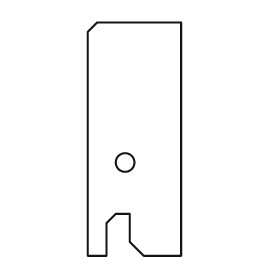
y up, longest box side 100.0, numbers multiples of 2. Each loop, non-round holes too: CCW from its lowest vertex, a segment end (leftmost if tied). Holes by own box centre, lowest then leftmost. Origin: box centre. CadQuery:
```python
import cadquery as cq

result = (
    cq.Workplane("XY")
    .moveTo(-20.0, -50.0)
    .lineTo(-12.0, -50.0)
    .lineTo(-12.0, -36.0)
    .lineTo(-8.0, -32.0)
    .lineTo(-2.0, -32.0)
    .lineTo(-2.0, -44.0)
    .lineTo(4.0, -50.0)
    .lineTo(20.0, -50.0)
    .lineTo(20.0, 50.0)
    .lineTo(-16.0, 50.0)
    .lineTo(-20.0, 46.0)
    .close()
    .moveTo(-4.0, -10.0)
    .circle(4.0)
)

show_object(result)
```